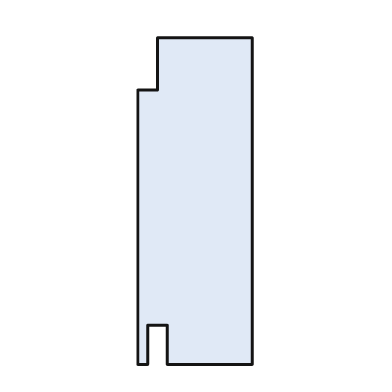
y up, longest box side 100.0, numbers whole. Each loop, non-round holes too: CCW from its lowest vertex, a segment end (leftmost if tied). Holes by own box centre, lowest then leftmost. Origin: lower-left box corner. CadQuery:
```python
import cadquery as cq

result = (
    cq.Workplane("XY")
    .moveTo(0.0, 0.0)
    .lineTo(3.0, 0.0)
    .lineTo(3.0, 12.0)
    .lineTo(9.0, 12.0)
    .lineTo(9.0, 0.0)
    .lineTo(35.0, 0.0)
    .lineTo(35.0, 100.0)
    .lineTo(6.0, 100.0)
    .lineTo(6.0, 84.0)
    .lineTo(0.0, 84.0)
    .close()
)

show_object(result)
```